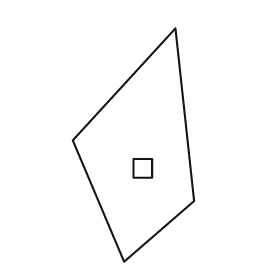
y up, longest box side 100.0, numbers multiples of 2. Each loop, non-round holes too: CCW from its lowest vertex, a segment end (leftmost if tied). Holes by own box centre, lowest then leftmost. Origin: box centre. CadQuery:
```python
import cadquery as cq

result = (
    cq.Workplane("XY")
    .moveTo(-4.0, -50.0)
    .lineTo(26.0, -24.0)
    .lineTo(18.0, 50.0)
    .lineTo(-26.0, 2.0)
    .close()
    .moveTo(0.0, -14.0)
    .lineTo(8.0, -14.0)
    .lineTo(8.0, -6.0)
    .lineTo(0.0, -6.0)
    .close()
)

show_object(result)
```